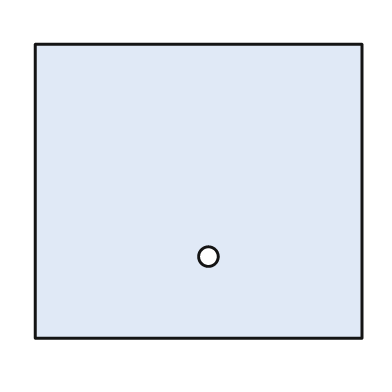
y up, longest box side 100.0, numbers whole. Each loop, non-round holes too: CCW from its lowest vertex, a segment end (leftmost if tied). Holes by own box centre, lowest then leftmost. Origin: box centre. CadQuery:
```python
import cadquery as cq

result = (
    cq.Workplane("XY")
    .moveTo(-50.0, -45.0)
    .lineTo(50.0, -45.0)
    .lineTo(50.0, 45.0)
    .lineTo(-50.0, 45.0)
    .close()
    .moveTo(3.0, -20.0)
    .circle(3.0)
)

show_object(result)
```